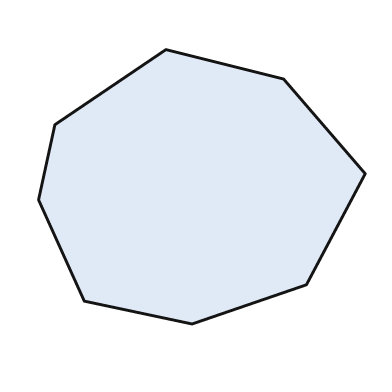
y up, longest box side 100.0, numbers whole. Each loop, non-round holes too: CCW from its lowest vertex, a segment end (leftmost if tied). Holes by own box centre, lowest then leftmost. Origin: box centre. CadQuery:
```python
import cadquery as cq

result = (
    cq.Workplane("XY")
    .moveTo(-3.0, -42.0)
    .lineTo(32.0, -30.0)
    .lineTo(50.0, 4.0)
    .lineTo(25.0, 33.0)
    .lineTo(-11.0, 42.0)
    .lineTo(-45.0, 19.0)
    .lineTo(-50.0, -4.0)
    .lineTo(-36.0, -35.0)
    .close()
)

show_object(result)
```